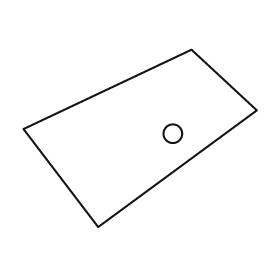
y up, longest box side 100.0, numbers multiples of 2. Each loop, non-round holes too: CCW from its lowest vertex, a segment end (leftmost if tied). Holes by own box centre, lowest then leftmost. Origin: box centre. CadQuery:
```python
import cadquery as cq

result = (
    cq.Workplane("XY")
    .moveTo(-18.0, -38.0)
    .lineTo(50.0, 12.0)
    .lineTo(22.0, 38.0)
    .lineTo(-50.0, 4.0)
    .close()
    .moveTo(14.0, 2.0)
    .circle(4.0)
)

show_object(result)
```